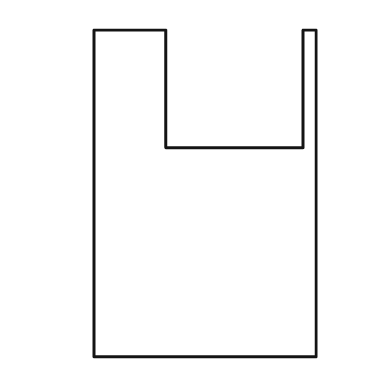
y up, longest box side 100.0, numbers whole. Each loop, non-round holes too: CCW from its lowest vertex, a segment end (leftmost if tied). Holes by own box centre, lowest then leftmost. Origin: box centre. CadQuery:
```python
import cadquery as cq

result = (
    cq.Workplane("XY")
    .moveTo(-34.0, -50.0)
    .lineTo(34.0, -50.0)
    .lineTo(34.0, 50.0)
    .lineTo(30.0, 50.0)
    .lineTo(30.0, 14.0)
    .lineTo(-12.0, 14.0)
    .lineTo(-12.0, 50.0)
    .lineTo(-34.0, 50.0)
    .close()
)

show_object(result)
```